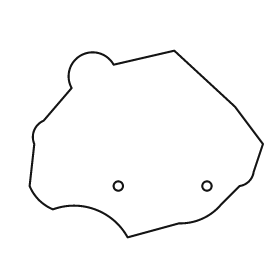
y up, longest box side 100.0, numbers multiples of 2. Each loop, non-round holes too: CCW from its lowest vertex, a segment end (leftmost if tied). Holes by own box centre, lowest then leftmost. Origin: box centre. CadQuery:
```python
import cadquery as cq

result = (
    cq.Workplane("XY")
    .moveTo(-8.0, -40.0)
    .lineTo(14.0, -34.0)
    .threePointArc((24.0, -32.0), (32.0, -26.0))
    .lineTo(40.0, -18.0)
    .threePointArc((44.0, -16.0), (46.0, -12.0))
    .lineTo(50.0, 0.0)
    .lineTo(38.0, 16.0)
    .lineTo(12.0, 40.0)
    .lineTo(-14.0, 34.0)
    .threePointArc((-28.0, 38.0), (-32.0, 24.0))
    .lineTo(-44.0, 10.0)
    .threePointArc((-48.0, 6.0), (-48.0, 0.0))
    .lineTo(-50.0, -18.0)
    .threePointArc((-46.0, -24.0), (-40.0, -28.0))
    .threePointArc((-22.0, -28.0), (-8.0, -40.0))
    .close()
    .moveTo(-12.0, -18.0)
    .circle(2.0)
    .moveTo(26.0, -18.0)
    .circle(2.0)
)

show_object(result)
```